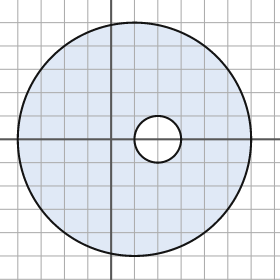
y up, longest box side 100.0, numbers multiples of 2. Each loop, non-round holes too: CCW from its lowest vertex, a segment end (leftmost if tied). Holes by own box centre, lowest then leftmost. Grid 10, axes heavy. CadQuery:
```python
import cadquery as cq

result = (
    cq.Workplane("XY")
    .moveTo(10.0, 0.0)
    .circle(50.0)
    .moveTo(20.0, 0.0)
    .circle(10.0)
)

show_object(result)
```